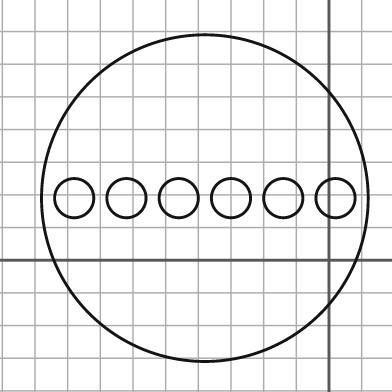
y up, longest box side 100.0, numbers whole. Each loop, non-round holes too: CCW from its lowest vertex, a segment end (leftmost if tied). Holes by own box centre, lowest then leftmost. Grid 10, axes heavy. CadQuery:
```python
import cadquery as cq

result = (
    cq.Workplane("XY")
    .moveTo(-38.0, 19.0)
    .circle(50.0)
    .moveTo(-78.0, 19.0)
    .circle(6.0)
    .moveTo(-62.0, 19.0)
    .circle(6.0)
    .moveTo(-46.0, 19.0)
    .circle(6.0)
    .moveTo(-30.0, 19.0)
    .circle(6.0)
    .moveTo(-14.0, 19.0)
    .circle(6.0)
    .moveTo(2.0, 19.0)
    .circle(6.0)
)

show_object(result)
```